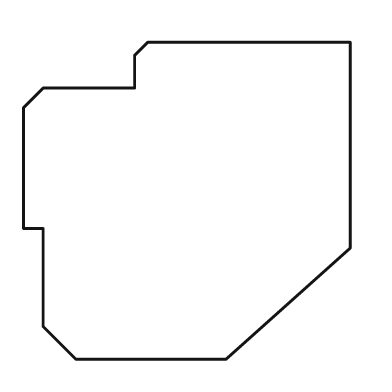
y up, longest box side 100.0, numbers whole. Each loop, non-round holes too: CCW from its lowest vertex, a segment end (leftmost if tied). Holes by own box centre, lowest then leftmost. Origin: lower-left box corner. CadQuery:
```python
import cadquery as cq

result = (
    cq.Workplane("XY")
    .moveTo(16.0, 0.0)
    .lineTo(62.0, 0.0)
    .lineTo(100.0, 34.0)
    .lineTo(100.0, 97.0)
    .lineTo(38.0, 97.0)
    .lineTo(34.0, 93.0)
    .lineTo(34.0, 83.0)
    .lineTo(6.0, 83.0)
    .lineTo(0.0, 77.0)
    .lineTo(0.0, 40.0)
    .lineTo(6.0, 40.0)
    .lineTo(6.0, 10.0)
    .close()
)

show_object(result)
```